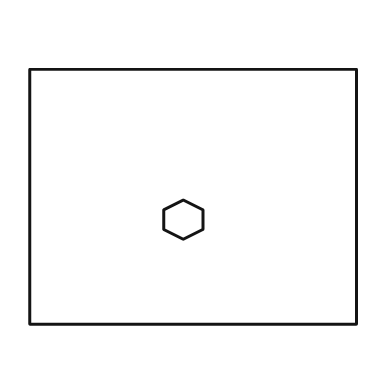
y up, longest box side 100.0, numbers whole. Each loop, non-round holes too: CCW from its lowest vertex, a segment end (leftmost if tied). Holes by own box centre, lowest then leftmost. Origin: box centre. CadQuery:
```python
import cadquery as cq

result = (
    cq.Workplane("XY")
    .moveTo(-50.0, -39.0)
    .lineTo(50.0, -39.0)
    .lineTo(50.0, 39.0)
    .lineTo(-50.0, 39.0)
    .close()
    .moveTo(-3.0, -13.0)
    .lineTo(3.0, -10.0)
    .lineTo(3.0, -4.0)
    .lineTo(-3.0, -1.0)
    .lineTo(-9.0, -4.0)
    .lineTo(-9.0, -10.0)
    .close()
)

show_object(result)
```